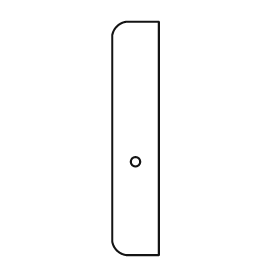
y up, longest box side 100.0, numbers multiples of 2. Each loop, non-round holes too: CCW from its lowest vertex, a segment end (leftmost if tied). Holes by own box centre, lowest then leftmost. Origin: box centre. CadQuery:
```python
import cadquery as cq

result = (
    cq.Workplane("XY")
    .moveTo(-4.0, -50.0)
    .lineTo(10.0, -50.0)
    .lineTo(10.0, 50.0)
    .lineTo(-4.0, 50.0)
    .threePointArc((-8.0, 48.0), (-10.0, 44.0))
    .lineTo(-10.0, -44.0)
    .threePointArc((-8.0, -48.0), (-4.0, -50.0))
    .close()
    .moveTo(0.0, -10.0)
    .circle(2.0)
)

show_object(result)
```